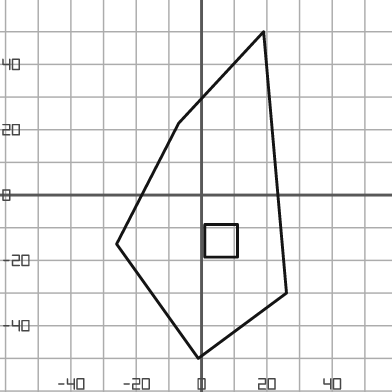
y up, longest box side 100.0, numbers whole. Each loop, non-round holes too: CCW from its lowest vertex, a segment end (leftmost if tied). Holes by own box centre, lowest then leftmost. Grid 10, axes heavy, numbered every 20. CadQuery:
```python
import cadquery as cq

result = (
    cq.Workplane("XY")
    .moveTo(-1.0, -50.0)
    .lineTo(26.0, -30.0)
    .lineTo(19.0, 50.0)
    .lineTo(-7.0, 22.0)
    .lineTo(-26.0, -15.0)
    .close()
    .moveTo(1.0, -19.0)
    .lineTo(11.0, -19.0)
    .lineTo(11.0, -9.0)
    .lineTo(1.0, -9.0)
    .close()
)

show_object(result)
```